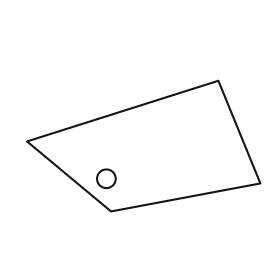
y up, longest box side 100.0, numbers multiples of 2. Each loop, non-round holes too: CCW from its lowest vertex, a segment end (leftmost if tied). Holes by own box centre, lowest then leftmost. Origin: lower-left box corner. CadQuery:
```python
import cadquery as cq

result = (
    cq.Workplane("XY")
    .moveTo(36.0, 0.0)
    .lineTo(100.0, 12.0)
    .lineTo(82.0, 56.0)
    .lineTo(0.0, 30.0)
    .close()
    .moveTo(34.0, 14.0)
    .circle(4.0)
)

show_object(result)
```